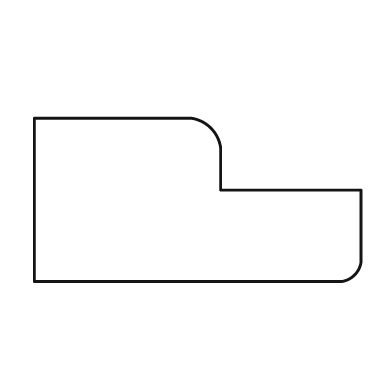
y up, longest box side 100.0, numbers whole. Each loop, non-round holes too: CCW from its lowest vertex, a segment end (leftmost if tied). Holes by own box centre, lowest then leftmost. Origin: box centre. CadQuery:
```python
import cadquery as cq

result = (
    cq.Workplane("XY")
    .moveTo(-50.0, -25.0)
    .lineTo(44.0, -25.0)
    .threePointArc((48.0, -23.0), (50.0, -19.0))
    .lineTo(50.0, 3.0)
    .lineTo(7.0, 3.0)
    .lineTo(7.0, 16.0)
    .threePointArc((4.0, 22.0), (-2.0, 25.0))
    .lineTo(-50.0, 25.0)
    .close()
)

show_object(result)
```